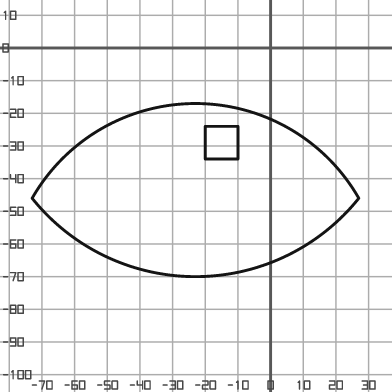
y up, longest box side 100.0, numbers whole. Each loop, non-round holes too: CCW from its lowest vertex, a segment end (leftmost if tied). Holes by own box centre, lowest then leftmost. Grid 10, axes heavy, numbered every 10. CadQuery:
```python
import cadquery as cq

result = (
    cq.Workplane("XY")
    .moveTo(-73.0, -46.0)
    .threePointArc((-23.0, -70.0), (27.0, -46.0))
    .threePointArc((-23.0, -17.0), (-73.0, -46.0))
    .close()
    .moveTo(-20.0, -34.0)
    .lineTo(-10.0, -34.0)
    .lineTo(-10.0, -24.0)
    .lineTo(-20.0, -24.0)
    .close()
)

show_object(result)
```